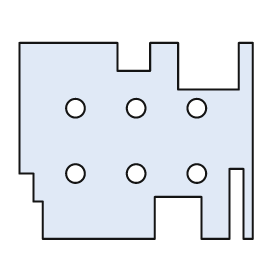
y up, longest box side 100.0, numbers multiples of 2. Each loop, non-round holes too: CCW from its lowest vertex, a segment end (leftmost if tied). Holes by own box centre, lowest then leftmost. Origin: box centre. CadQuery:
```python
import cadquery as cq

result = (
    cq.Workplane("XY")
    .moveTo(-40.0, -42.0)
    .lineTo(8.0, -42.0)
    .lineTo(8.0, -24.0)
    .lineTo(28.0, -24.0)
    .lineTo(28.0, -42.0)
    .lineTo(40.0, -42.0)
    .lineTo(40.0, -12.0)
    .lineTo(46.0, -12.0)
    .lineTo(46.0, -42.0)
    .lineTo(50.0, -42.0)
    .lineTo(50.0, 42.0)
    .lineTo(44.0, 42.0)
    .lineTo(44.0, 22.0)
    .lineTo(18.0, 22.0)
    .lineTo(18.0, 42.0)
    .lineTo(6.0, 42.0)
    .lineTo(6.0, 30.0)
    .lineTo(-8.0, 30.0)
    .lineTo(-8.0, 42.0)
    .lineTo(-50.0, 42.0)
    .lineTo(-50.0, -14.0)
    .lineTo(-44.0, -14.0)
    .lineTo(-44.0, -26.0)
    .lineTo(-40.0, -26.0)
    .close()
    .moveTo(-26.0, -14.0)
    .circle(4.0)
    .moveTo(0.0, -14.0)
    .circle(4.0)
    .moveTo(26.0, -14.0)
    .circle(4.0)
    .moveTo(-26.0, 14.0)
    .circle(4.0)
    .moveTo(0.0, 14.0)
    .circle(4.0)
    .moveTo(26.0, 14.0)
    .circle(4.0)
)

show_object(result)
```